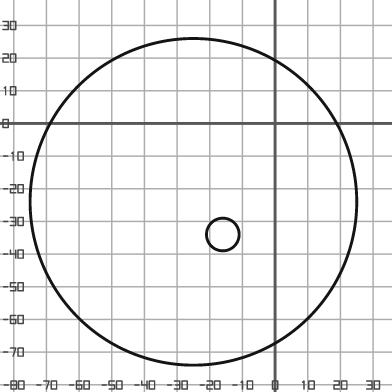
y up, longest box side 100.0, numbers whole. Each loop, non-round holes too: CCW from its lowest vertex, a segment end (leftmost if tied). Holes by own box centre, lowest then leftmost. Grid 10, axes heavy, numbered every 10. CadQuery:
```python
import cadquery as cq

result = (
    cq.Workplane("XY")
    .moveTo(-25.0, -24.0)
    .circle(50.0)
    .moveTo(-16.0, -34.0)
    .circle(5.0)
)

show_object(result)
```